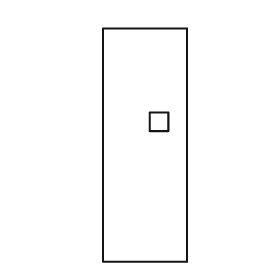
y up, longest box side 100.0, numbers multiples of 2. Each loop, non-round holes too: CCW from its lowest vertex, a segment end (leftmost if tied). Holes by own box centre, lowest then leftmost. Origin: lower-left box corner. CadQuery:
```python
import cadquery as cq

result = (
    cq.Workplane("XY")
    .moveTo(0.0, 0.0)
    .lineTo(36.0, 0.0)
    .lineTo(36.0, 100.0)
    .lineTo(0.0, 100.0)
    .close()
    .moveTo(20.0, 56.0)
    .lineTo(28.0, 56.0)
    .lineTo(28.0, 64.0)
    .lineTo(20.0, 64.0)
    .close()
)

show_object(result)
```